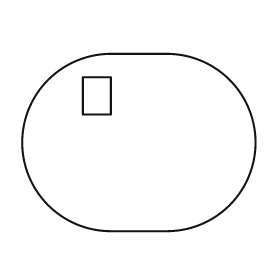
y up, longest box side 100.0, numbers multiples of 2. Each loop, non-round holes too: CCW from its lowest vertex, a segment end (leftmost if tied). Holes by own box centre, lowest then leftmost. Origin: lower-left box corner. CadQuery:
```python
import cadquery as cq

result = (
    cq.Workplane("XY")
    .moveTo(38.0, 0.0)
    .lineTo(62.0, 0.0)
    .threePointArc((100.0, 38.0), (62.0, 76.0))
    .lineTo(38.0, 76.0)
    .threePointArc((0.0, 38.0), (38.0, 0.0))
    .close()
    .moveTo(26.0, 50.0)
    .lineTo(38.0, 50.0)
    .lineTo(38.0, 66.0)
    .lineTo(26.0, 66.0)
    .close()
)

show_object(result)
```